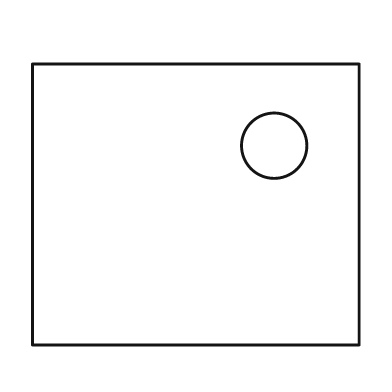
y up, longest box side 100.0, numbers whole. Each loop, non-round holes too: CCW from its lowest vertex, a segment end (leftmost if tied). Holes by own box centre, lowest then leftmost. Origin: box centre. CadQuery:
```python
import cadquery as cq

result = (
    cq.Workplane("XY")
    .moveTo(-50.0, -43.0)
    .lineTo(50.0, -43.0)
    .lineTo(50.0, 43.0)
    .lineTo(-50.0, 43.0)
    .close()
    .moveTo(24.0, 18.0)
    .circle(10.0)
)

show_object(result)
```